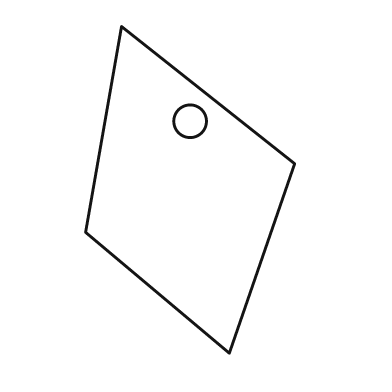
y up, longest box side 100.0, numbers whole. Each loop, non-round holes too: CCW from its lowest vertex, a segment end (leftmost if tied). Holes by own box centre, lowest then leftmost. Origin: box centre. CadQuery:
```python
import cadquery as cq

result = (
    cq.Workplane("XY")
    .moveTo(12.0, -50.0)
    .lineTo(32.0, 8.0)
    .lineTo(-21.0, 50.0)
    .lineTo(-32.0, -13.0)
    .close()
    .moveTo(0.0, 21.0)
    .circle(5.0)
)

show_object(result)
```